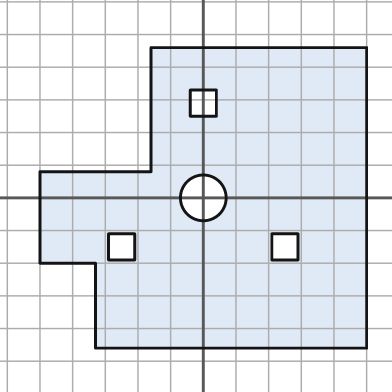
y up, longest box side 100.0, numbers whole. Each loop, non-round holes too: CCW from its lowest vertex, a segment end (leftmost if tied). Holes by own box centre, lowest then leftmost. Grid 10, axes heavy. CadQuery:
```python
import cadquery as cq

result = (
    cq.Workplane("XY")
    .moveTo(-33.0, -46.0)
    .lineTo(50.0, -46.0)
    .lineTo(50.0, 46.0)
    .lineTo(-16.0, 46.0)
    .lineTo(-16.0, 8.0)
    .lineTo(-50.0, 8.0)
    .lineTo(-50.0, -20.0)
    .lineTo(-33.0, -20.0)
    .close()
    .moveTo(-29.0, -19.0)
    .lineTo(-21.0, -19.0)
    .lineTo(-21.0, -11.0)
    .lineTo(-29.0, -11.0)
    .close()
    .moveTo(21.0, -19.0)
    .lineTo(29.0, -19.0)
    .lineTo(29.0, -11.0)
    .lineTo(21.0, -11.0)
    .close()
    .moveTo(0.0, 0.0)
    .circle(7.0)
    .moveTo(-4.0, 25.0)
    .lineTo(4.0, 25.0)
    .lineTo(4.0, 33.0)
    .lineTo(-4.0, 33.0)
    .close()
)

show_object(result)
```